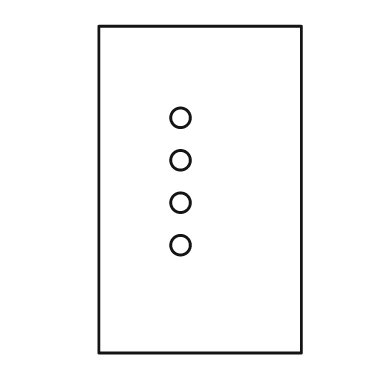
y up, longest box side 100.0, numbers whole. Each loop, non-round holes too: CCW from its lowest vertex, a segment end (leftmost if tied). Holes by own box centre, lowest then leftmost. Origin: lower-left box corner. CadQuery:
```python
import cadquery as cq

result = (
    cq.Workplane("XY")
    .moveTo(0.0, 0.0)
    .lineTo(62.0, 0.0)
    .lineTo(62.0, 100.0)
    .lineTo(0.0, 100.0)
    .close()
    .moveTo(25.0, 33.0)
    .circle(3.0)
    .moveTo(25.0, 46.0)
    .circle(3.0)
    .moveTo(25.0, 59.0)
    .circle(3.0)
    .moveTo(25.0, 72.0)
    .circle(3.0)
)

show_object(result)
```